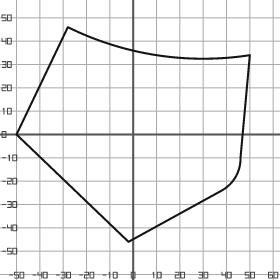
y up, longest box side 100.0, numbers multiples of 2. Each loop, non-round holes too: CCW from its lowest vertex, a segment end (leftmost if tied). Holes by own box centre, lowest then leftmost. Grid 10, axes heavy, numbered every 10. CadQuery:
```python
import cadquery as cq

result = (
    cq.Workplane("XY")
    .moveTo(-2.0, -46.0)
    .lineTo(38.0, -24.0)
    .threePointArc((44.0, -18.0), (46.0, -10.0))
    .lineTo(50.0, 34.0)
    .threePointArc((10.0, 34.0), (-28.0, 46.0))
    .lineTo(-50.0, 0.0)
    .close()
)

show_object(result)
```